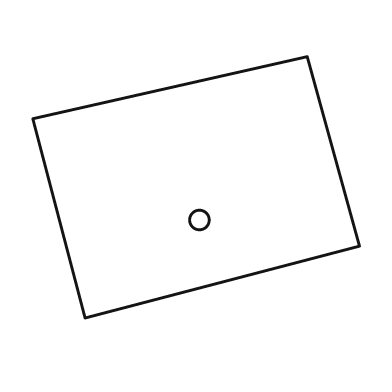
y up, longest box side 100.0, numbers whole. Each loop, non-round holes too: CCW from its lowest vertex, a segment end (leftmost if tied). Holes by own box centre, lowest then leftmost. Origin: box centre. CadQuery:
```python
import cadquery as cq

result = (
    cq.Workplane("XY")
    .moveTo(-34.0, -40.0)
    .lineTo(50.0, -18.0)
    .lineTo(34.0, 40.0)
    .lineTo(-50.0, 21.0)
    .close()
    .moveTo(1.0, -10.0)
    .circle(3.0)
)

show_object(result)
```